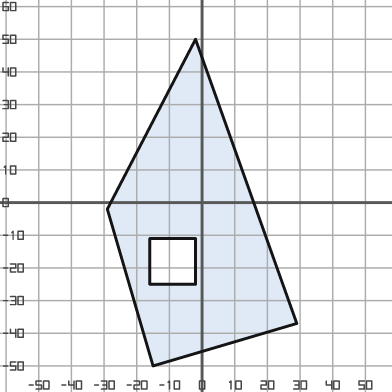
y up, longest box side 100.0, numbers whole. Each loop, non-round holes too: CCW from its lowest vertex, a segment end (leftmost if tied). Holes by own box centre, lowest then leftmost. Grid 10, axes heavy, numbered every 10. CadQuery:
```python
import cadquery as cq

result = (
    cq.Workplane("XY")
    .moveTo(-15.0, -50.0)
    .lineTo(29.0, -37.0)
    .lineTo(-2.0, 50.0)
    .lineTo(-29.0, -2.0)
    .close()
    .moveTo(-16.0, -25.0)
    .lineTo(-2.0, -25.0)
    .lineTo(-2.0, -11.0)
    .lineTo(-16.0, -11.0)
    .close()
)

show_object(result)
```